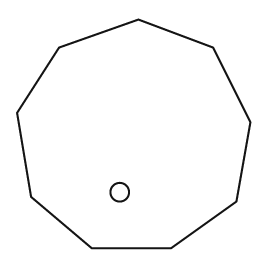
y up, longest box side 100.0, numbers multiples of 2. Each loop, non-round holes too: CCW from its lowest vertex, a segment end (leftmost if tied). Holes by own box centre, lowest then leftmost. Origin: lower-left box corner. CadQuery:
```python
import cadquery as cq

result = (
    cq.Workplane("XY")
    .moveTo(32.0, 0.0)
    .lineTo(66.0, 0.0)
    .lineTo(94.0, 20.0)
    .lineTo(100.0, 54.0)
    .lineTo(84.0, 86.0)
    .lineTo(52.0, 98.0)
    .lineTo(18.0, 86.0)
    .lineTo(0.0, 58.0)
    .lineTo(6.0, 22.0)
    .close()
    .moveTo(44.0, 24.0)
    .circle(4.0)
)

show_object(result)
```